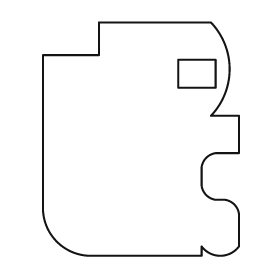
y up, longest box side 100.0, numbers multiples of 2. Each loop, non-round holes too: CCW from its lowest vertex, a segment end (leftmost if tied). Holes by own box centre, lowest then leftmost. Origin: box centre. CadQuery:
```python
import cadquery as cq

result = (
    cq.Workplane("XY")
    .moveTo(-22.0, -50.0)
    .lineTo(26.0, -50.0)
    .lineTo(26.0, -46.0)
    .threePointArc((34.0, -50.0), (42.0, -46.0))
    .lineTo(42.0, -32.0)
    .threePointArc((40.0, -28.0), (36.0, -26.0))
    .lineTo(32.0, -26.0)
    .threePointArc((28.0, -24.0), (26.0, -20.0))
    .lineTo(26.0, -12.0)
    .threePointArc((28.0, -8.0), (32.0, -6.0))
    .lineTo(42.0, -6.0)
    .lineTo(42.0, 10.0)
    .lineTo(30.0, 10.0)
    .threePointArc((38.0, 30.0), (30.0, 50.0))
    .lineTo(-18.0, 50.0)
    .lineTo(-18.0, 36.0)
    .lineTo(-42.0, 36.0)
    .lineTo(-42.0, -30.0)
    .threePointArc((-36.0, -44.0), (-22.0, -50.0))
    .close()
    .moveTo(16.0, 22.0)
    .lineTo(32.0, 22.0)
    .lineTo(32.0, 34.0)
    .lineTo(16.0, 34.0)
    .close()
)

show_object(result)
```